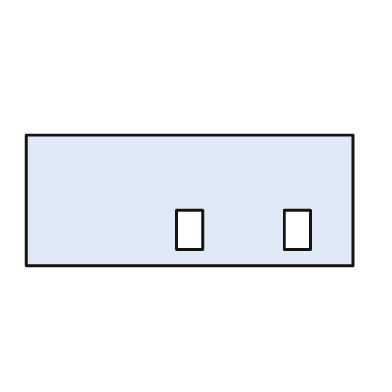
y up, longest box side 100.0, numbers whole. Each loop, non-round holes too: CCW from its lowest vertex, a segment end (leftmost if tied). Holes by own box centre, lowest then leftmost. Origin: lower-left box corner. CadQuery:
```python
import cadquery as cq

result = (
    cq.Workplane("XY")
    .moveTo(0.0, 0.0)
    .lineTo(100.0, 0.0)
    .lineTo(100.0, 40.0)
    .lineTo(0.0, 40.0)
    .close()
    .moveTo(46.0, 5.0)
    .lineTo(54.0, 5.0)
    .lineTo(54.0, 17.0)
    .lineTo(46.0, 17.0)
    .close()
    .moveTo(79.0, 5.0)
    .lineTo(87.0, 5.0)
    .lineTo(87.0, 17.0)
    .lineTo(79.0, 17.0)
    .close()
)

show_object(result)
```